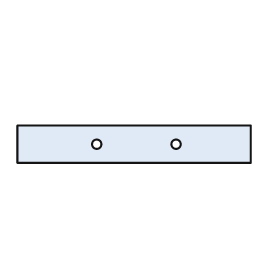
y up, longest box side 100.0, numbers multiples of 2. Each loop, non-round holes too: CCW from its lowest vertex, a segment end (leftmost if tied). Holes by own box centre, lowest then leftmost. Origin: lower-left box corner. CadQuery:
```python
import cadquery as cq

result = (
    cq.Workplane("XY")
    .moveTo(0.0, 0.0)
    .lineTo(100.0, 0.0)
    .lineTo(100.0, 16.0)
    .lineTo(0.0, 16.0)
    .close()
    .moveTo(34.0, 8.0)
    .circle(2.0)
    .moveTo(68.0, 8.0)
    .circle(2.0)
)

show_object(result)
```